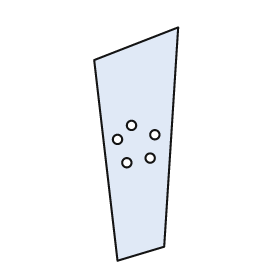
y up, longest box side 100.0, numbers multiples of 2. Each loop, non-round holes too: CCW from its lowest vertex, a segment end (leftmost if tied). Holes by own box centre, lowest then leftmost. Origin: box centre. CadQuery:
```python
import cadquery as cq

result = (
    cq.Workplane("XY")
    .moveTo(-8.0, -50.0)
    .lineTo(12.0, -44.0)
    .lineTo(18.0, 50.0)
    .lineTo(-18.0, 36.0)
    .close()
    .moveTo(-4.0, -8.0)
    .circle(2.0)
    .moveTo(6.0, -6.0)
    .circle(2.0)
    .moveTo(-8.0, 2.0)
    .circle(2.0)
    .moveTo(8.0, 4.0)
    .circle(2.0)
    .moveTo(-2.0, 8.0)
    .circle(2.0)
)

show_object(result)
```